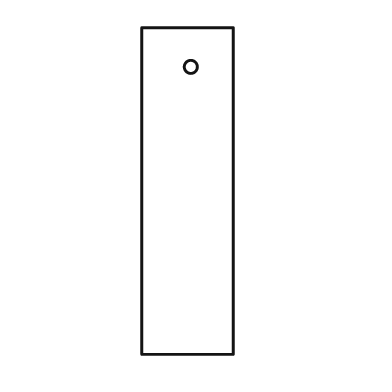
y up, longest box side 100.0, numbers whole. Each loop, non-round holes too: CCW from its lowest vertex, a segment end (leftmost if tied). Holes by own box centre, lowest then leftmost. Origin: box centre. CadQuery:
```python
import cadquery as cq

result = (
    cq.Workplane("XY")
    .moveTo(-14.0, -50.0)
    .lineTo(14.0, -50.0)
    .lineTo(14.0, 50.0)
    .lineTo(-14.0, 50.0)
    .close()
    .moveTo(1.0, 38.0)
    .circle(2.0)
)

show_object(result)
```